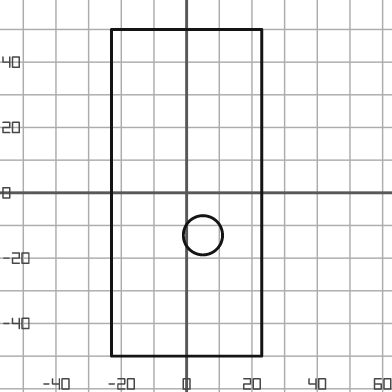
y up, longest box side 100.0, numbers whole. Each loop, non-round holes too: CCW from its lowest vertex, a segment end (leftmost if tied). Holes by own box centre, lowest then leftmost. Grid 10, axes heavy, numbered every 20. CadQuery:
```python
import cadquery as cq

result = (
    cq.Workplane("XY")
    .moveTo(-23.0, -50.0)
    .lineTo(23.0, -50.0)
    .lineTo(23.0, 50.0)
    .lineTo(-23.0, 50.0)
    .close()
    .moveTo(5.0, -13.0)
    .circle(6.0)
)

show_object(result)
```